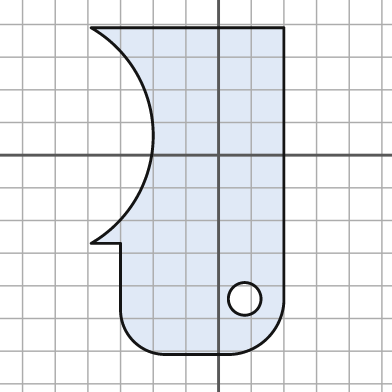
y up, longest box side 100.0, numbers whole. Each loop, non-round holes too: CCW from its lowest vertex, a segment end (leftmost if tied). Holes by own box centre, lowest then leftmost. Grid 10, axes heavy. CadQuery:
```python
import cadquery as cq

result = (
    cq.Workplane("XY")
    .moveTo(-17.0, -61.0)
    .lineTo(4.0, -61.0)
    .threePointArc((15.0, -56.0), (20.0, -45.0))
    .lineTo(20.0, 39.0)
    .lineTo(-39.0, 39.0)
    .threePointArc((-20.0, 6.0), (-39.0, -27.0))
    .lineTo(-30.0, -27.0)
    .lineTo(-30.0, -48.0)
    .threePointArc((-26.0, -57.0), (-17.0, -61.0))
    .close()
    .moveTo(8.0, -44.0)
    .circle(5.0)
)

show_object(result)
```